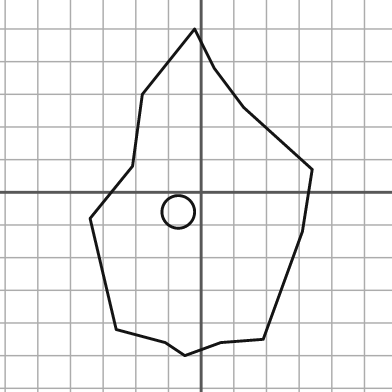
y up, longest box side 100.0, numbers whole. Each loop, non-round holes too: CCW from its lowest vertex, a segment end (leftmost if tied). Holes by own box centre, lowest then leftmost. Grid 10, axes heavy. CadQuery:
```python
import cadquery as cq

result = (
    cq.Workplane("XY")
    .moveTo(-5.0, -50.0)
    .lineTo(6.0, -46.0)
    .lineTo(19.0, -45.0)
    .lineTo(31.0, -12.0)
    .lineTo(34.0, 7.0)
    .lineTo(13.0, 26.0)
    .lineTo(4.0, 38.0)
    .lineTo(-2.0, 50.0)
    .lineTo(-18.0, 30.0)
    .lineTo(-21.0, 8.0)
    .lineTo(-34.0, -8.0)
    .lineTo(-26.0, -42.0)
    .lineTo(-11.0, -46.0)
    .close()
    .moveTo(-7.0, -6.0)
    .circle(5.0)
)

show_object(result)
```